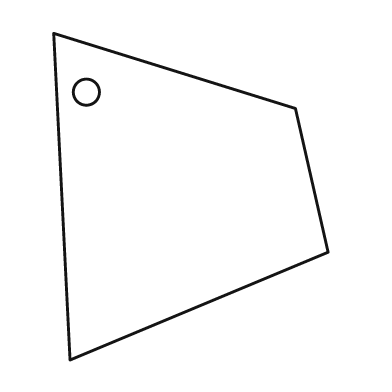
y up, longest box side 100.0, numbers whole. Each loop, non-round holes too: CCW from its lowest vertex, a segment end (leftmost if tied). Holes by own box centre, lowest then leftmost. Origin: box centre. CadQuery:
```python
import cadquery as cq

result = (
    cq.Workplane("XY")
    .moveTo(-37.0, -50.0)
    .lineTo(42.0, -17.0)
    .lineTo(32.0, 27.0)
    .lineTo(-42.0, 50.0)
    .close()
    .moveTo(-32.0, 32.0)
    .circle(4.0)
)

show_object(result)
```